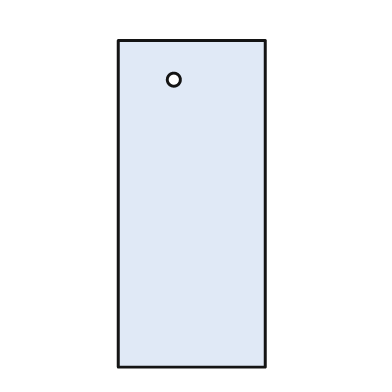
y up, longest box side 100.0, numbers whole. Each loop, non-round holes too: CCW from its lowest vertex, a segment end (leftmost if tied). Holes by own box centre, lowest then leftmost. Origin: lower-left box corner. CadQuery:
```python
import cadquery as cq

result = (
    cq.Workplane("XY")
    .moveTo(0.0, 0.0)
    .lineTo(45.0, 0.0)
    .lineTo(45.0, 100.0)
    .lineTo(0.0, 100.0)
    .close()
    .moveTo(17.0, 88.0)
    .circle(2.0)
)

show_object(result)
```